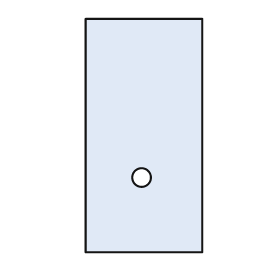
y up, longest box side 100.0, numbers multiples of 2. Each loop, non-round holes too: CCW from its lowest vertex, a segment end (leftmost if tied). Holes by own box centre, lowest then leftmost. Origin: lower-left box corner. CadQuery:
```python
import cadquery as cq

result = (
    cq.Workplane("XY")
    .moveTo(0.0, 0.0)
    .lineTo(50.0, 0.0)
    .lineTo(50.0, 100.0)
    .lineTo(0.0, 100.0)
    .close()
    .moveTo(24.0, 32.0)
    .circle(4.0)
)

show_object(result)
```